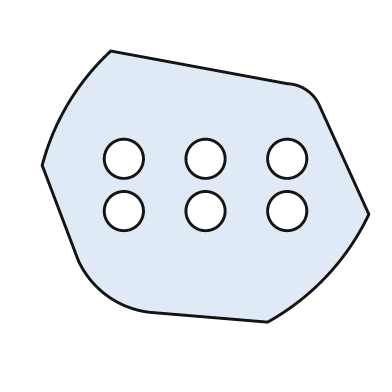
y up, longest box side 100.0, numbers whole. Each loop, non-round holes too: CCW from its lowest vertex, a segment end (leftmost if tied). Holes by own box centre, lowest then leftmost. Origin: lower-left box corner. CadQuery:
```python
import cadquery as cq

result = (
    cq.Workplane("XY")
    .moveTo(69.0, 0.0)
    .threePointArc((87.0, 14.0), (100.0, 33.0))
    .lineTo(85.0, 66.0)
    .threePointArc((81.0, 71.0), (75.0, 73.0))
    .lineTo(21.0, 83.0)
    .threePointArc((8.0, 67.0), (0.0, 48.0))
    .lineTo(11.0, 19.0)
    .threePointArc((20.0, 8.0), (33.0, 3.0))
    .close()
    .moveTo(25.0, 34.0)
    .circle(6.0)
    .moveTo(50.0, 34.0)
    .circle(6.0)
    .moveTo(75.0, 34.0)
    .circle(6.0)
    .moveTo(25.0, 50.0)
    .circle(6.0)
    .moveTo(50.0, 50.0)
    .circle(6.0)
    .moveTo(75.0, 50.0)
    .circle(6.0)
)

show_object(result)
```